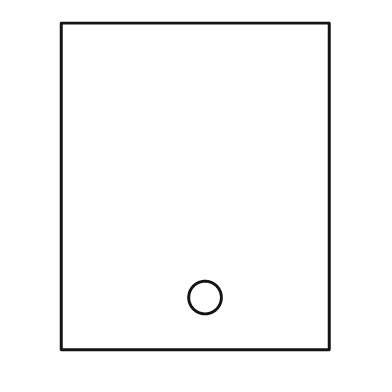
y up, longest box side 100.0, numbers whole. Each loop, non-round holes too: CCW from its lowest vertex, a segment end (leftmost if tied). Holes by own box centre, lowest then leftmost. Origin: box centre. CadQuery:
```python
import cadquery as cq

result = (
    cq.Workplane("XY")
    .moveTo(-41.0, -50.0)
    .lineTo(41.0, -50.0)
    .lineTo(41.0, 50.0)
    .lineTo(-41.0, 50.0)
    .close()
    .moveTo(3.0, -34.0)
    .circle(5.0)
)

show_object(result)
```